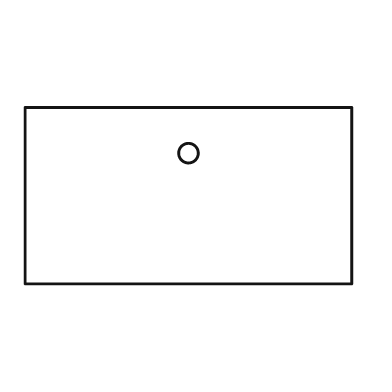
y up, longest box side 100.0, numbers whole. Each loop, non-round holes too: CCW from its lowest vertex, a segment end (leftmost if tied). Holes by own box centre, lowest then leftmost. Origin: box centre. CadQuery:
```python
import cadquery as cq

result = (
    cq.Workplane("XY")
    .moveTo(-50.0, -27.0)
    .lineTo(50.0, -27.0)
    .lineTo(50.0, 27.0)
    .lineTo(-50.0, 27.0)
    .close()
    .moveTo(0.0, 13.0)
    .circle(3.0)
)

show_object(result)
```